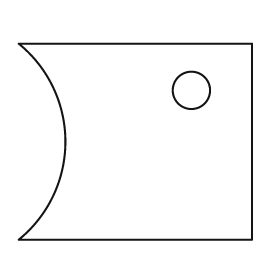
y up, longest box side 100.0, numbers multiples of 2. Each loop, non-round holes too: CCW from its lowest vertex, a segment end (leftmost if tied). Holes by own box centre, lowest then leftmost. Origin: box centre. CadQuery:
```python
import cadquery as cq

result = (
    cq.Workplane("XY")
    .moveTo(-50.0, -42.0)
    .lineTo(50.0, -42.0)
    .lineTo(50.0, 42.0)
    .lineTo(-50.0, 42.0)
    .threePointArc((-30.0, 0.0), (-50.0, -42.0))
    .close()
    .moveTo(24.0, 22.0)
    .circle(8.0)
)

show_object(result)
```